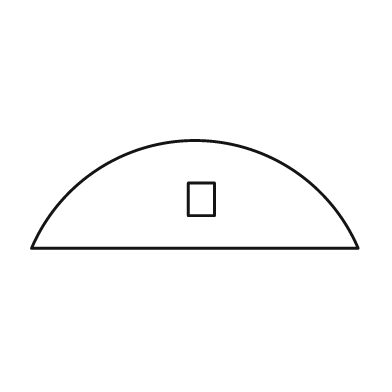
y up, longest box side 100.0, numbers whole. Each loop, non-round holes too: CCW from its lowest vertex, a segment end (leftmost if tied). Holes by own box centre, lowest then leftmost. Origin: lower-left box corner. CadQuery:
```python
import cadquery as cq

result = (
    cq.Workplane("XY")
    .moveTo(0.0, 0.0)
    .lineTo(100.0, 0.0)
    .threePointArc((50.0, 33.0), (0.0, 0.0))
    .close()
    .moveTo(48.0, 10.0)
    .lineTo(56.0, 10.0)
    .lineTo(56.0, 20.0)
    .lineTo(48.0, 20.0)
    .close()
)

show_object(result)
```